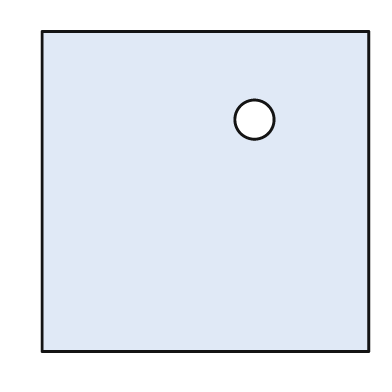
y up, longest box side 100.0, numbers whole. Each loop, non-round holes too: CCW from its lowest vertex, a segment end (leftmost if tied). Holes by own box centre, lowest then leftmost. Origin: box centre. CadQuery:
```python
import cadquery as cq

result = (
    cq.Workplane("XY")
    .moveTo(-50.0, -49.0)
    .lineTo(50.0, -49.0)
    .lineTo(50.0, 49.0)
    .lineTo(-50.0, 49.0)
    .close()
    .moveTo(15.0, 22.0)
    .circle(6.0)
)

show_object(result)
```